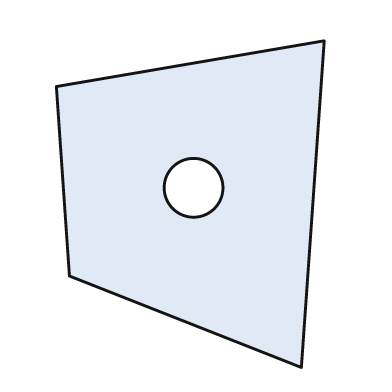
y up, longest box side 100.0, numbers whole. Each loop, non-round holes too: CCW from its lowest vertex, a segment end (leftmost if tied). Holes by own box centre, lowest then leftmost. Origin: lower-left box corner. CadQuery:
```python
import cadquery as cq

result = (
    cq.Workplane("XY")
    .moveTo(75.0, 0.0)
    .lineTo(82.0, 100.0)
    .lineTo(0.0, 86.0)
    .lineTo(4.0, 28.0)
    .close()
    .moveTo(42.0, 55.0)
    .circle(9.0)
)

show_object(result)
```